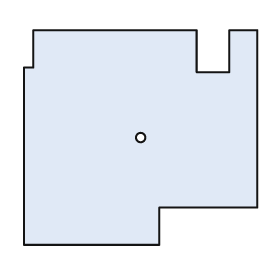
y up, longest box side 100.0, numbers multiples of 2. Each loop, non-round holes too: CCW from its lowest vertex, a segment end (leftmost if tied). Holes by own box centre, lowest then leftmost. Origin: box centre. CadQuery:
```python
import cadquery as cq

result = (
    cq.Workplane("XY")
    .moveTo(-50.0, -46.0)
    .lineTo(8.0, -46.0)
    .lineTo(8.0, -30.0)
    .lineTo(50.0, -30.0)
    .lineTo(50.0, 46.0)
    .lineTo(38.0, 46.0)
    .lineTo(38.0, 28.0)
    .lineTo(24.0, 28.0)
    .lineTo(24.0, 46.0)
    .lineTo(-46.0, 46.0)
    .lineTo(-46.0, 30.0)
    .lineTo(-50.0, 30.0)
    .close()
    .moveTo(0.0, 0.0)
    .circle(2.0)
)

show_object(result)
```